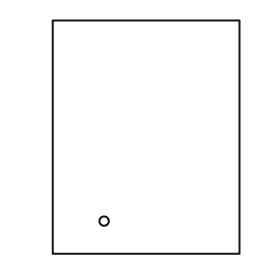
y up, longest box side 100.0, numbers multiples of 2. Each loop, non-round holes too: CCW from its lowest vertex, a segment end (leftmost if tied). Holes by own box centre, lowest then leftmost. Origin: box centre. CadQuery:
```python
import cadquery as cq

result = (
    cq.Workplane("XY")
    .moveTo(-40.0, -50.0)
    .lineTo(40.0, -50.0)
    .lineTo(40.0, 50.0)
    .lineTo(-40.0, 50.0)
    .close()
    .moveTo(-18.0, -36.0)
    .circle(2.0)
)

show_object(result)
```